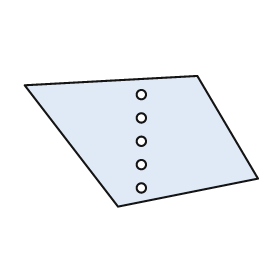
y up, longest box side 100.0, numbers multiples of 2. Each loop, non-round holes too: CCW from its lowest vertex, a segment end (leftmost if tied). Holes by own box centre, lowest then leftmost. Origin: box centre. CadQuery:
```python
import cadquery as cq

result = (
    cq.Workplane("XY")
    .moveTo(-10.0, -28.0)
    .lineTo(50.0, -16.0)
    .lineTo(24.0, 28.0)
    .lineTo(-50.0, 24.0)
    .close()
    .moveTo(0.0, -20.0)
    .circle(2.0)
    .moveTo(0.0, -10.0)
    .circle(2.0)
    .moveTo(0.0, 0.0)
    .circle(2.0)
    .moveTo(0.0, 10.0)
    .circle(2.0)
    .moveTo(0.0, 20.0)
    .circle(2.0)
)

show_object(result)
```